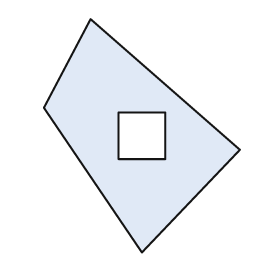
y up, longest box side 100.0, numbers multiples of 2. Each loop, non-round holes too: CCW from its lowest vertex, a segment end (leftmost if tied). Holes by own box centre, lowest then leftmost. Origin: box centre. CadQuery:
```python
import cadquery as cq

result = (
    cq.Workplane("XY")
    .moveTo(0.0, -50.0)
    .lineTo(42.0, -6.0)
    .lineTo(-22.0, 50.0)
    .lineTo(-42.0, 12.0)
    .close()
    .moveTo(-10.0, -10.0)
    .lineTo(10.0, -10.0)
    .lineTo(10.0, 10.0)
    .lineTo(-10.0, 10.0)
    .close()
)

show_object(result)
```